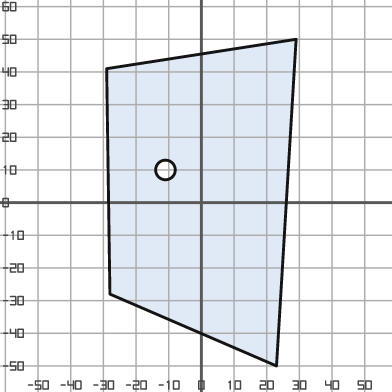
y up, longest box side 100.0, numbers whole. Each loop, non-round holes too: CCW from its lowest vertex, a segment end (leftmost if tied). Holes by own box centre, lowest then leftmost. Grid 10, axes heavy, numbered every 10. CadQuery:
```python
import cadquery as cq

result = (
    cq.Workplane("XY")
    .moveTo(23.0, -50.0)
    .lineTo(29.0, 50.0)
    .lineTo(-29.0, 41.0)
    .lineTo(-28.0, -28.0)
    .close()
    .moveTo(-11.0, 10.0)
    .circle(3.0)
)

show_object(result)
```